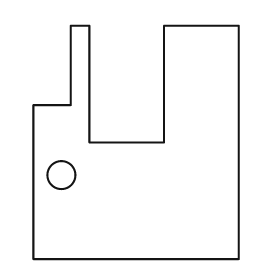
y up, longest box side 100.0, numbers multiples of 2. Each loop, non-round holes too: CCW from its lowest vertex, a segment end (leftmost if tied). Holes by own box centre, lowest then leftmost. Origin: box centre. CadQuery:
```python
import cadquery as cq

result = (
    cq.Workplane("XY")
    .moveTo(-44.0, -50.0)
    .lineTo(44.0, -50.0)
    .lineTo(44.0, 50.0)
    .lineTo(12.0, 50.0)
    .lineTo(12.0, 0.0)
    .lineTo(-20.0, 0.0)
    .lineTo(-20.0, 50.0)
    .lineTo(-28.0, 50.0)
    .lineTo(-28.0, 16.0)
    .lineTo(-44.0, 16.0)
    .close()
    .moveTo(-32.0, -14.0)
    .circle(6.0)
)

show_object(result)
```